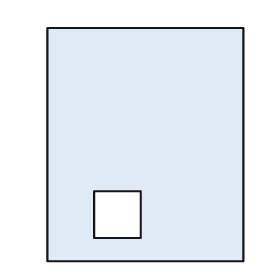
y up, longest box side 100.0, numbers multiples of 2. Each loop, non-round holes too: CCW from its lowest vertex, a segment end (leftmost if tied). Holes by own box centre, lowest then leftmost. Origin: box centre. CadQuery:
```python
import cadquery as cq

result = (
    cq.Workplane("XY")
    .moveTo(-42.0, -50.0)
    .lineTo(42.0, -50.0)
    .lineTo(42.0, 50.0)
    .lineTo(-42.0, 50.0)
    .close()
    .moveTo(-22.0, -40.0)
    .lineTo(-2.0, -40.0)
    .lineTo(-2.0, -20.0)
    .lineTo(-22.0, -20.0)
    .close()
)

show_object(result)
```